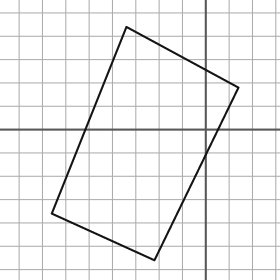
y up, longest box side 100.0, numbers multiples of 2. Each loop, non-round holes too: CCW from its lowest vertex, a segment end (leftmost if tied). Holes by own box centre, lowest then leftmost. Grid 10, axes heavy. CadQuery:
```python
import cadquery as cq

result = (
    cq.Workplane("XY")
    .moveTo(-22.0, -56.0)
    .lineTo(14.0, 18.0)
    .lineTo(-34.0, 44.0)
    .lineTo(-66.0, -36.0)
    .close()
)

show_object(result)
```